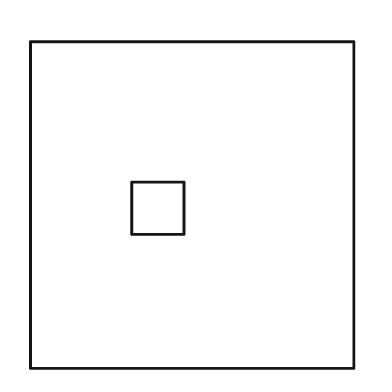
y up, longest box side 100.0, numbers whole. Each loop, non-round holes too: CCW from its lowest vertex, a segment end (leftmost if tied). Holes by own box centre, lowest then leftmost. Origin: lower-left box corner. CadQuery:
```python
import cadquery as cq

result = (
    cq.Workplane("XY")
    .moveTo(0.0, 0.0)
    .lineTo(99.0, 0.0)
    .lineTo(99.0, 100.0)
    .lineTo(0.0, 100.0)
    .close()
    .moveTo(31.0, 41.0)
    .lineTo(47.0, 41.0)
    .lineTo(47.0, 57.0)
    .lineTo(31.0, 57.0)
    .close()
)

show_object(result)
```